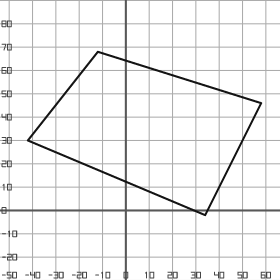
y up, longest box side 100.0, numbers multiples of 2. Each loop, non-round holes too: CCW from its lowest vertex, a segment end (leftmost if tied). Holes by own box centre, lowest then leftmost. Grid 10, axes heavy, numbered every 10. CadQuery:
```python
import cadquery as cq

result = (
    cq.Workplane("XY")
    .moveTo(34.0, -2.0)
    .lineTo(58.0, 46.0)
    .lineTo(-12.0, 68.0)
    .lineTo(-42.0, 30.0)
    .close()
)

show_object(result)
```